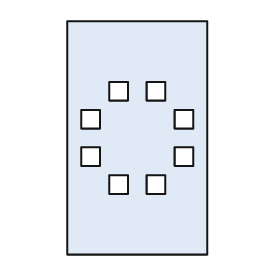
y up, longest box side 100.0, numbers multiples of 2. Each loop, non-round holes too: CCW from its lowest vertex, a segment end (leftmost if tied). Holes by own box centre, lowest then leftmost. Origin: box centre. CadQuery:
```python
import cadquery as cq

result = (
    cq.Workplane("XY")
    .moveTo(-30.0, -50.0)
    .lineTo(30.0, -50.0)
    .lineTo(30.0, 50.0)
    .lineTo(-30.0, 50.0)
    .close()
    .moveTo(-12.0, -24.0)
    .lineTo(-4.0, -24.0)
    .lineTo(-4.0, -16.0)
    .lineTo(-12.0, -16.0)
    .close()
    .moveTo(4.0, -24.0)
    .lineTo(12.0, -24.0)
    .lineTo(12.0, -16.0)
    .lineTo(4.0, -16.0)
    .close()
    .moveTo(-24.0, -12.0)
    .lineTo(-16.0, -12.0)
    .lineTo(-16.0, -4.0)
    .lineTo(-24.0, -4.0)
    .close()
    .moveTo(16.0, -12.0)
    .lineTo(24.0, -12.0)
    .lineTo(24.0, -4.0)
    .lineTo(16.0, -4.0)
    .close()
    .moveTo(-24.0, 4.0)
    .lineTo(-16.0, 4.0)
    .lineTo(-16.0, 12.0)
    .lineTo(-24.0, 12.0)
    .close()
    .moveTo(16.0, 4.0)
    .lineTo(24.0, 4.0)
    .lineTo(24.0, 12.0)
    .lineTo(16.0, 12.0)
    .close()
    .moveTo(-12.0, 16.0)
    .lineTo(-4.0, 16.0)
    .lineTo(-4.0, 24.0)
    .lineTo(-12.0, 24.0)
    .close()
    .moveTo(4.0, 16.0)
    .lineTo(12.0, 16.0)
    .lineTo(12.0, 24.0)
    .lineTo(4.0, 24.0)
    .close()
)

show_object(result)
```